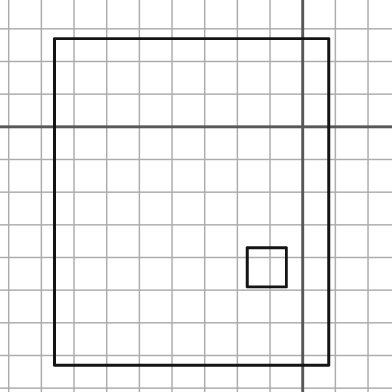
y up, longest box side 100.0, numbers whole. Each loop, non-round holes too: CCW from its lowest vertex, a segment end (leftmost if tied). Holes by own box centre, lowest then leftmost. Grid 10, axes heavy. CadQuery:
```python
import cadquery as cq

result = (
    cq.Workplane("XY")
    .moveTo(-76.0, -73.0)
    .lineTo(8.0, -73.0)
    .lineTo(8.0, 27.0)
    .lineTo(-76.0, 27.0)
    .close()
    .moveTo(-17.0, -49.0)
    .lineTo(-5.0, -49.0)
    .lineTo(-5.0, -37.0)
    .lineTo(-17.0, -37.0)
    .close()
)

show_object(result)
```